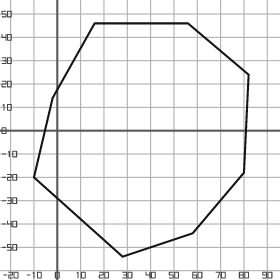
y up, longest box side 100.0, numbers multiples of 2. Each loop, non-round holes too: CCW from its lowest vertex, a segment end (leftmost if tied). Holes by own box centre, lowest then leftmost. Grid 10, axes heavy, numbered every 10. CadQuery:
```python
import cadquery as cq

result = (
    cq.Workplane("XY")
    .moveTo(28.0, -54.0)
    .lineTo(58.0, -44.0)
    .lineTo(80.0, -18.0)
    .lineTo(82.0, 24.0)
    .lineTo(56.0, 46.0)
    .lineTo(16.0, 46.0)
    .lineTo(-2.0, 14.0)
    .lineTo(-10.0, -20.0)
    .close()
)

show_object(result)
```